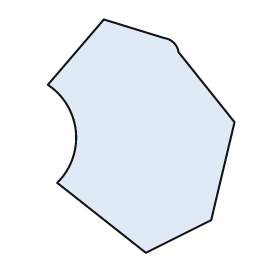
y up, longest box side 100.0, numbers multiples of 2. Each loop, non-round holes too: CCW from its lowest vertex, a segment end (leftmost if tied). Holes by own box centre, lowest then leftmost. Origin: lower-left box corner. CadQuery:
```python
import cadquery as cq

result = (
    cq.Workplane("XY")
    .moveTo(42.0, 0.0)
    .lineTo(70.0, 14.0)
    .lineTo(80.0, 56.0)
    .lineTo(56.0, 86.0)
    .threePointArc((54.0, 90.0), (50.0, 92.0))
    .lineTo(24.0, 100.0)
    .lineTo(0.0, 72.0)
    .threePointArc((12.0, 52.0), (4.0, 30.0))
    .close()
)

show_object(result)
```